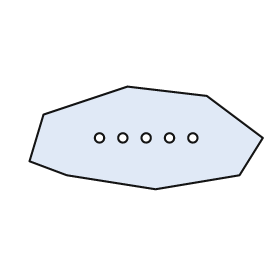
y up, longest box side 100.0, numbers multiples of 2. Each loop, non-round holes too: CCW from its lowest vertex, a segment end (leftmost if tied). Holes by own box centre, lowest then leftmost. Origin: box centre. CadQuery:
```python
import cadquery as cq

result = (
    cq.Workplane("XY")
    .moveTo(4.0, -22.0)
    .lineTo(40.0, -16.0)
    .lineTo(50.0, 0.0)
    .lineTo(26.0, 18.0)
    .lineTo(-8.0, 22.0)
    .lineTo(-44.0, 10.0)
    .lineTo(-50.0, -10.0)
    .lineTo(-34.0, -16.0)
    .close()
    .moveTo(-20.0, 0.0)
    .circle(2.0)
    .moveTo(-10.0, 0.0)
    .circle(2.0)
    .moveTo(0.0, 0.0)
    .circle(2.0)
    .moveTo(10.0, 0.0)
    .circle(2.0)
    .moveTo(20.0, 0.0)
    .circle(2.0)
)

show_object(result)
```